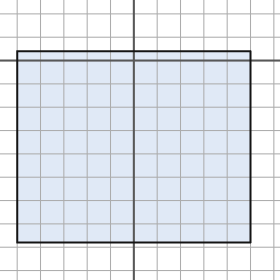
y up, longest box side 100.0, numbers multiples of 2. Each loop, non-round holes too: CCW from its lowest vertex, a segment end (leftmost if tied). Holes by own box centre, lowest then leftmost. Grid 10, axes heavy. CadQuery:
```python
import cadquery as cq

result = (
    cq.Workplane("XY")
    .moveTo(-50.0, -78.0)
    .lineTo(50.0, -78.0)
    .lineTo(50.0, 4.0)
    .lineTo(-50.0, 4.0)
    .close()
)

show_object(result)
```